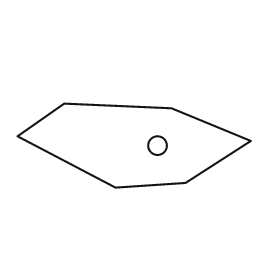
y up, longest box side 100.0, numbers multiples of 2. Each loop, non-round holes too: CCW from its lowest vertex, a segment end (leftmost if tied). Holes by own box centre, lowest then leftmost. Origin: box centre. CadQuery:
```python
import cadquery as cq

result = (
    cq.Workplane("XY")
    .moveTo(-8.0, -18.0)
    .lineTo(22.0, -16.0)
    .lineTo(50.0, 2.0)
    .lineTo(16.0, 16.0)
    .lineTo(-30.0, 18.0)
    .lineTo(-50.0, 4.0)
    .close()
    .moveTo(10.0, 0.0)
    .circle(4.0)
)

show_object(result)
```